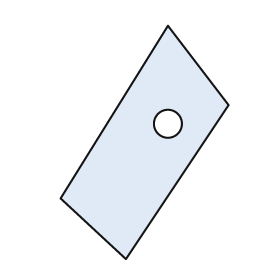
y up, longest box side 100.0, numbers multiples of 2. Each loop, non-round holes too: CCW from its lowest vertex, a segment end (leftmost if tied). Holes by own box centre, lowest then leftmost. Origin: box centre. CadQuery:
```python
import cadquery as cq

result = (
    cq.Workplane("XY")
    .moveTo(-8.0, -50.0)
    .lineTo(36.0, 16.0)
    .lineTo(10.0, 50.0)
    .lineTo(-36.0, -24.0)
    .close()
    .moveTo(10.0, 8.0)
    .circle(6.0)
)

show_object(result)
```